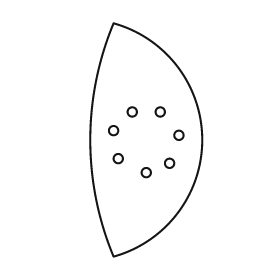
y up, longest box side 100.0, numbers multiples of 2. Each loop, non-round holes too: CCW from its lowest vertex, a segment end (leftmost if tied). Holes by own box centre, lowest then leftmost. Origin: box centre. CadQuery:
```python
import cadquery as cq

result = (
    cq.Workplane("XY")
    .moveTo(-14.0, -50.0)
    .threePointArc((24.0, 0.0), (-14.0, 50.0))
    .threePointArc((-24.0, 0.0), (-14.0, -50.0))
    .close()
    .moveTo(0.0, -14.0)
    .circle(2.0)
    .moveTo(10.0, -10.0)
    .circle(2.0)
    .moveTo(-12.0, -8.0)
    .circle(2.0)
    .moveTo(14.0, 2.0)
    .circle(2.0)
    .moveTo(-14.0, 4.0)
    .circle(2.0)
    .moveTo(-6.0, 12.0)
    .circle(2.0)
    .moveTo(6.0, 12.0)
    .circle(2.0)
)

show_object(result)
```